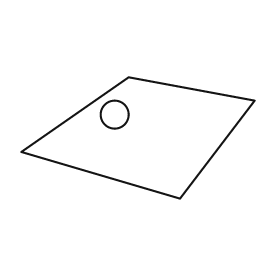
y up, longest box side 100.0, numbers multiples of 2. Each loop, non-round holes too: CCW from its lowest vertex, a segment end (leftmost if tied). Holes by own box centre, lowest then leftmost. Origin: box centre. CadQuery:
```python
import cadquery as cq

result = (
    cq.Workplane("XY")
    .moveTo(18.0, -26.0)
    .lineTo(50.0, 16.0)
    .lineTo(-4.0, 26.0)
    .lineTo(-50.0, -6.0)
    .close()
    .moveTo(-10.0, 10.0)
    .circle(6.0)
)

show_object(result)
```